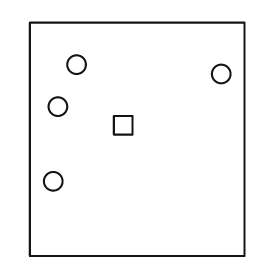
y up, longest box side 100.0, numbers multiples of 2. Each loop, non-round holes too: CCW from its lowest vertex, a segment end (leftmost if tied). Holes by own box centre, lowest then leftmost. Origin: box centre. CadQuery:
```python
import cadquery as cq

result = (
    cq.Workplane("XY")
    .moveTo(-46.0, -50.0)
    .lineTo(46.0, -50.0)
    .lineTo(46.0, 50.0)
    .lineTo(-46.0, 50.0)
    .close()
    .moveTo(-36.0, -18.0)
    .circle(4.0)
    .moveTo(-10.0, 2.0)
    .lineTo(-2.0, 2.0)
    .lineTo(-2.0, 10.0)
    .lineTo(-10.0, 10.0)
    .close()
    .moveTo(-34.0, 14.0)
    .circle(4.0)
    .moveTo(36.0, 28.0)
    .circle(4.0)
    .moveTo(-26.0, 32.0)
    .circle(4.0)
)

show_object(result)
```